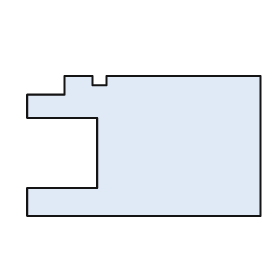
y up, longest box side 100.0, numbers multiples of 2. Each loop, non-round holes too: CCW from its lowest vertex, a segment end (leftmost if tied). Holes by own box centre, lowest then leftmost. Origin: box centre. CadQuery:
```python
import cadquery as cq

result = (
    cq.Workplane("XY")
    .moveTo(-50.0, -30.0)
    .lineTo(50.0, -30.0)
    .lineTo(50.0, 30.0)
    .lineTo(-16.0, 30.0)
    .lineTo(-16.0, 26.0)
    .lineTo(-22.0, 26.0)
    .lineTo(-22.0, 30.0)
    .lineTo(-34.0, 30.0)
    .lineTo(-34.0, 22.0)
    .lineTo(-50.0, 22.0)
    .lineTo(-50.0, 12.0)
    .lineTo(-20.0, 12.0)
    .lineTo(-20.0, -18.0)
    .lineTo(-50.0, -18.0)
    .close()
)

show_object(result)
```